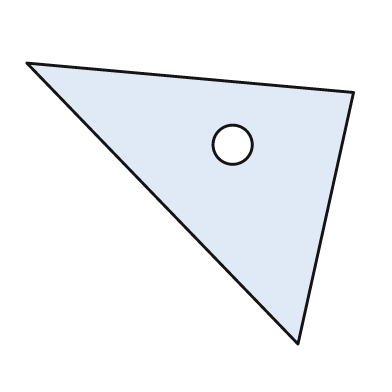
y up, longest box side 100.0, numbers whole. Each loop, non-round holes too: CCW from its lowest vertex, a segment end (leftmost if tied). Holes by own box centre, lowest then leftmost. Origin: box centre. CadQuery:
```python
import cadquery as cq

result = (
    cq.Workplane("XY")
    .moveTo(33.0, -43.0)
    .lineTo(50.0, 34.0)
    .lineTo(-50.0, 43.0)
    .close()
    .moveTo(13.0, 18.0)
    .circle(6.0)
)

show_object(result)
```